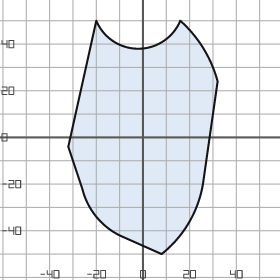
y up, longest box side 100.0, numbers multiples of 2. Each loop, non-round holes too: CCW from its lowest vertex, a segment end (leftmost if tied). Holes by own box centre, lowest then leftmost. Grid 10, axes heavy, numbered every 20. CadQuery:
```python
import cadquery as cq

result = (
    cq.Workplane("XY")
    .moveTo(8.0, -50.0)
    .threePointArc((20.0, -36.0), (26.0, -18.0))
    .lineTo(32.0, 24.0)
    .threePointArc((26.0, 38.0), (16.0, 50.0))
    .threePointArc((-2.0, 38.0), (-20.0, 50.0))
    .lineTo(-32.0, -4.0)
    .lineTo(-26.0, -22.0)
    .threePointArc((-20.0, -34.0), (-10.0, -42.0))
    .close()
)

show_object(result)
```